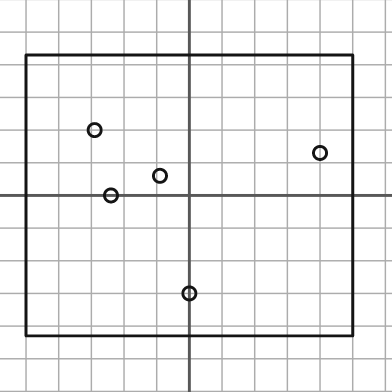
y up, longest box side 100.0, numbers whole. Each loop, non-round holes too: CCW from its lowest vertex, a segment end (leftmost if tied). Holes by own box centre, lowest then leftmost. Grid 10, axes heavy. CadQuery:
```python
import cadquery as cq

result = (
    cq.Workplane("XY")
    .moveTo(-50.0, -43.0)
    .lineTo(50.0, -43.0)
    .lineTo(50.0, 43.0)
    .lineTo(-50.0, 43.0)
    .close()
    .moveTo(0.0, -30.0)
    .circle(2.0)
    .moveTo(-24.0, 0.0)
    .circle(2.0)
    .moveTo(-9.0, 6.0)
    .circle(2.0)
    .moveTo(40.0, 13.0)
    .circle(2.0)
    .moveTo(-29.0, 20.0)
    .circle(2.0)
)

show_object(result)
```